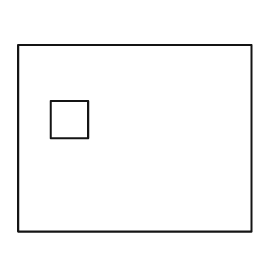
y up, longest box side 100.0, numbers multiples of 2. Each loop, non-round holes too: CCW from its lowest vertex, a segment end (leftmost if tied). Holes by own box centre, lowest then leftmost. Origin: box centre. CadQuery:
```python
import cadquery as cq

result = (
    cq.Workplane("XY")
    .moveTo(-50.0, -40.0)
    .lineTo(50.0, -40.0)
    .lineTo(50.0, 40.0)
    .lineTo(-50.0, 40.0)
    .close()
    .moveTo(-36.0, 0.0)
    .lineTo(-20.0, 0.0)
    .lineTo(-20.0, 16.0)
    .lineTo(-36.0, 16.0)
    .close()
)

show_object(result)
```